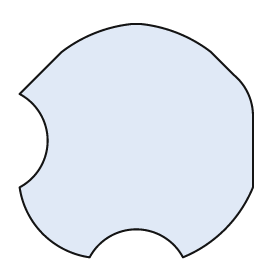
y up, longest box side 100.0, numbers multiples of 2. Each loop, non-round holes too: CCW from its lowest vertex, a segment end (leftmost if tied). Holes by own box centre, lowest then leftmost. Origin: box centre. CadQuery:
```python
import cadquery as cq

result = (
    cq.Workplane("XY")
    .moveTo(-20.0, -50.0)
    .threePointArc((0.0, -38.0), (20.0, -50.0))
    .threePointArc((38.0, -38.0), (50.0, -20.0))
    .lineTo(50.0, 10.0)
    .threePointArc((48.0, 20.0), (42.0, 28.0))
    .lineTo(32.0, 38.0)
    .threePointArc((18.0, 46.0), (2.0, 50.0))
    .lineTo(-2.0, 50.0)
    .threePointArc((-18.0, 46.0), (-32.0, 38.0))
    .lineTo(-50.0, 20.0)
    .threePointArc((-38.0, 0.0), (-50.0, -20.0))
    .threePointArc((-40.0, -40.0), (-20.0, -50.0))
    .close()
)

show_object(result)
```